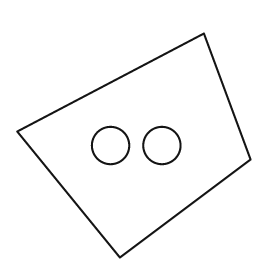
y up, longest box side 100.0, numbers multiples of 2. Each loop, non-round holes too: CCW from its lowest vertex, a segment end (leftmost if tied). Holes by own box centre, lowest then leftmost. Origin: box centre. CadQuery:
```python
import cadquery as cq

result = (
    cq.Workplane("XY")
    .moveTo(-6.0, -48.0)
    .lineTo(50.0, -6.0)
    .lineTo(30.0, 48.0)
    .lineTo(-50.0, 6.0)
    .close()
    .moveTo(-10.0, 0.0)
    .circle(8.0)
    .moveTo(12.0, 0.0)
    .circle(8.0)
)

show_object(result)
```